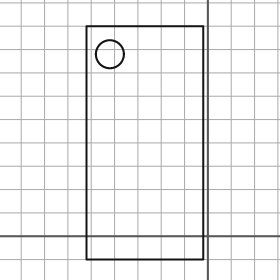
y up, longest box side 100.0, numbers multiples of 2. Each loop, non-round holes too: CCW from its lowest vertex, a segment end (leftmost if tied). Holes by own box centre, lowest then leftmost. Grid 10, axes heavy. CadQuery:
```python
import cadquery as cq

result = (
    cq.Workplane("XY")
    .moveTo(-52.0, -10.0)
    .lineTo(-2.0, -10.0)
    .lineTo(-2.0, 90.0)
    .lineTo(-52.0, 90.0)
    .close()
    .moveTo(-42.0, 78.0)
    .circle(6.0)
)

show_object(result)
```